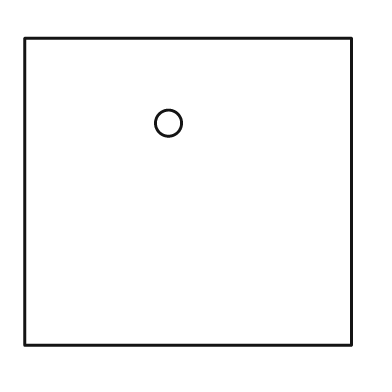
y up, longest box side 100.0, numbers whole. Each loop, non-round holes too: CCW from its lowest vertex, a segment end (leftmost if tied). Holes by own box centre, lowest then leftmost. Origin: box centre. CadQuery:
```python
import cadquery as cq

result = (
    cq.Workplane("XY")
    .moveTo(-50.0, -47.0)
    .lineTo(50.0, -47.0)
    .lineTo(50.0, 47.0)
    .lineTo(-50.0, 47.0)
    .close()
    .moveTo(-6.0, 21.0)
    .circle(4.0)
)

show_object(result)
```